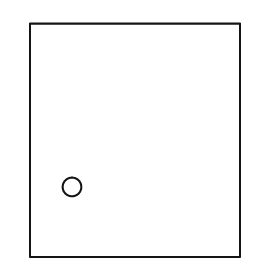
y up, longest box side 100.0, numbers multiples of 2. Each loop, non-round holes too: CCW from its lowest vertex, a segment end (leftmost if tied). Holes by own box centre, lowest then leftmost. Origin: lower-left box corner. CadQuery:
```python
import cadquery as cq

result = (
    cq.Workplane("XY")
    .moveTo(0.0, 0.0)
    .lineTo(90.0, 0.0)
    .lineTo(90.0, 100.0)
    .lineTo(0.0, 100.0)
    .close()
    .moveTo(18.0, 30.0)
    .circle(4.0)
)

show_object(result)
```